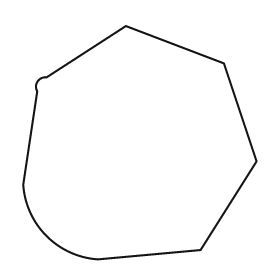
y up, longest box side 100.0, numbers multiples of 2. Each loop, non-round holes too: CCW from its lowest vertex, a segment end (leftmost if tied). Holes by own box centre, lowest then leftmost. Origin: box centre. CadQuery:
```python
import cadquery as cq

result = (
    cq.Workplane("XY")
    .moveTo(-18.0, -50.0)
    .lineTo(26.0, -46.0)
    .lineTo(50.0, -8.0)
    .lineTo(36.0, 34.0)
    .lineTo(-6.0, 50.0)
    .lineTo(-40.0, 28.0)
    .threePointArc((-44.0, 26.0), (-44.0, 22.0))
    .lineTo(-50.0, -18.0)
    .threePointArc((-40.0, -40.0), (-18.0, -50.0))
    .close()
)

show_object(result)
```